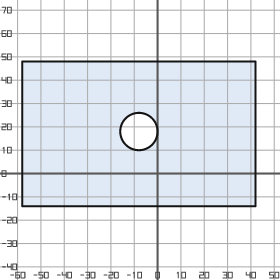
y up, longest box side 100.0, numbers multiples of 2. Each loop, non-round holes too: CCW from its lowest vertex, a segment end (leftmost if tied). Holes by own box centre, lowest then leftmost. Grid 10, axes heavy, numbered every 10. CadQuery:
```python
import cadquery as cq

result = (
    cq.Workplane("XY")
    .moveTo(-58.0, -14.0)
    .lineTo(42.0, -14.0)
    .lineTo(42.0, 48.0)
    .lineTo(-58.0, 48.0)
    .close()
    .moveTo(-8.0, 18.0)
    .circle(8.0)
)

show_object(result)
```